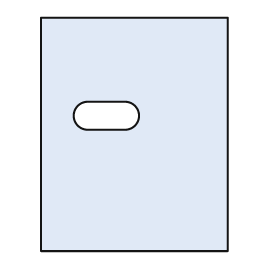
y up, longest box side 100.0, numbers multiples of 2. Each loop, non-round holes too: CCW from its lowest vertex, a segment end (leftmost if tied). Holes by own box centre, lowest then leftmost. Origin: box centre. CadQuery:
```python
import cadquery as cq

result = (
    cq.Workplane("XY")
    .moveTo(-40.0, -50.0)
    .lineTo(40.0, -50.0)
    .lineTo(40.0, 50.0)
    .lineTo(-40.0, 50.0)
    .close()
    .moveTo(-20.0, 2.0)
    .lineTo(-4.0, 2.0)
    .threePointArc((2.0, 8.0), (-4.0, 14.0))
    .lineTo(-20.0, 14.0)
    .threePointArc((-26.0, 8.0), (-20.0, 2.0))
    .close()
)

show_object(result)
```